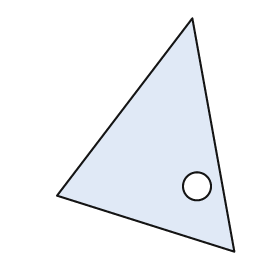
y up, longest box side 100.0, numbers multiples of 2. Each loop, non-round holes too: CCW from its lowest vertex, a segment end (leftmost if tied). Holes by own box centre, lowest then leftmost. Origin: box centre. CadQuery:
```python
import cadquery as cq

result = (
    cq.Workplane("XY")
    .moveTo(38.0, -50.0)
    .lineTo(20.0, 50.0)
    .lineTo(-38.0, -26.0)
    .close()
    .moveTo(22.0, -22.0)
    .circle(6.0)
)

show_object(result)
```